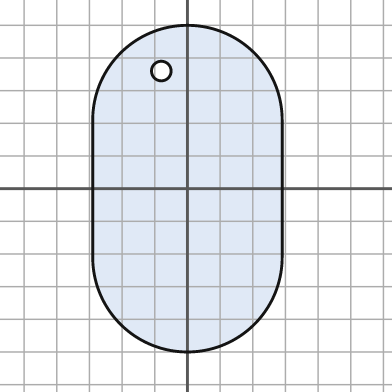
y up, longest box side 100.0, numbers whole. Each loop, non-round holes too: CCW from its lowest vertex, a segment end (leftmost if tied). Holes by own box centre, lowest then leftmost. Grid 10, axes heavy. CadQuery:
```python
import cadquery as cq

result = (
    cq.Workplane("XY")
    .moveTo(-29.0, -21.0)
    .threePointArc((0.0, -50.0), (29.0, -21.0))
    .lineTo(29.0, 21.0)
    .threePointArc((0.0, 50.0), (-29.0, 21.0))
    .close()
    .moveTo(-8.0, 36.0)
    .circle(3.0)
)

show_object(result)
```